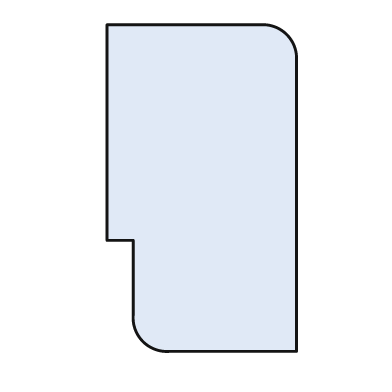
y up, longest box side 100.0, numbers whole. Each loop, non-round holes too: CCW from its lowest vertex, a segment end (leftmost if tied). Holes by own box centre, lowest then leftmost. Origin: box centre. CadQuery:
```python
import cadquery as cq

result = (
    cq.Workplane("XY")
    .moveTo(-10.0, -50.0)
    .lineTo(29.0, -50.0)
    .lineTo(29.0, 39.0)
    .threePointArc((26.0, 47.0), (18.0, 50.0))
    .lineTo(-29.0, 50.0)
    .lineTo(-29.0, -16.0)
    .lineTo(-21.0, -16.0)
    .lineTo(-21.0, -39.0)
    .threePointArc((-18.0, -47.0), (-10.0, -50.0))
    .close()
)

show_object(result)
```